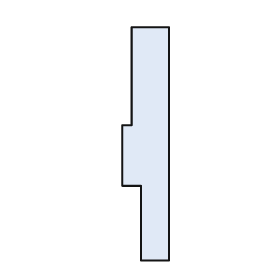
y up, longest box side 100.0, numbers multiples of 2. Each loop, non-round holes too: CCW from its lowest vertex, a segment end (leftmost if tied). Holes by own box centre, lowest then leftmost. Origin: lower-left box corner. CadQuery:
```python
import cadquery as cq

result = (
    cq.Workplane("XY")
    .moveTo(8.0, 0.0)
    .lineTo(20.0, 0.0)
    .lineTo(20.0, 100.0)
    .lineTo(4.0, 100.0)
    .lineTo(4.0, 58.0)
    .lineTo(0.0, 58.0)
    .lineTo(0.0, 32.0)
    .lineTo(8.0, 32.0)
    .close()
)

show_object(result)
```